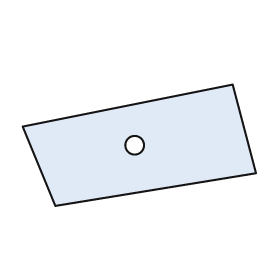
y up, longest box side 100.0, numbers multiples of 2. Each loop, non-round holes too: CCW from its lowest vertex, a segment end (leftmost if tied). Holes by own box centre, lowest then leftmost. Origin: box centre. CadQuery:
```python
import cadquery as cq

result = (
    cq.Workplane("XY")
    .moveTo(-36.0, -26.0)
    .lineTo(50.0, -12.0)
    .lineTo(40.0, 26.0)
    .lineTo(-50.0, 8.0)
    .close()
    .moveTo(-2.0, 0.0)
    .circle(4.0)
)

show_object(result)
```